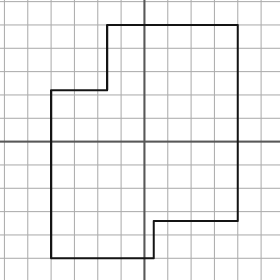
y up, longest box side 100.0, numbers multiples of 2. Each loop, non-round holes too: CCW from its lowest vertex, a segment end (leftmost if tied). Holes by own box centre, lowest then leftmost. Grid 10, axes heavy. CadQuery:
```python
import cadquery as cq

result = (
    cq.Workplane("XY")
    .moveTo(-40.0, -50.0)
    .lineTo(4.0, -50.0)
    .lineTo(4.0, -34.0)
    .lineTo(40.0, -34.0)
    .lineTo(40.0, 50.0)
    .lineTo(-16.0, 50.0)
    .lineTo(-16.0, 22.0)
    .lineTo(-40.0, 22.0)
    .close()
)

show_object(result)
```